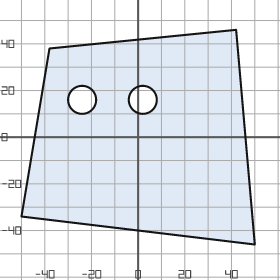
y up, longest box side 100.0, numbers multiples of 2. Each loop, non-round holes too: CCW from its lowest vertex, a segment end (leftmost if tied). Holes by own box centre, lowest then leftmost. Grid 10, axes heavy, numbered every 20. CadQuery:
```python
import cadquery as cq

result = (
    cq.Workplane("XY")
    .moveTo(50.0, -46.0)
    .lineTo(42.0, 46.0)
    .lineTo(-38.0, 38.0)
    .lineTo(-50.0, -34.0)
    .close()
    .moveTo(-24.0, 16.0)
    .circle(6.0)
    .moveTo(2.0, 16.0)
    .circle(6.0)
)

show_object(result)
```